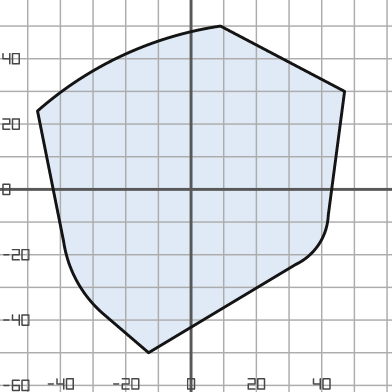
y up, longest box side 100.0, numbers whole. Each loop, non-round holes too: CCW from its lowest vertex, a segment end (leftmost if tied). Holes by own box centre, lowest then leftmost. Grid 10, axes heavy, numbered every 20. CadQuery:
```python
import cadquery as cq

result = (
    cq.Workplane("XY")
    .moveTo(-13.0, -50.0)
    .lineTo(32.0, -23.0)
    .threePointArc((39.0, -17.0), (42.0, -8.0))
    .lineTo(47.0, 30.0)
    .lineTo(9.0, 50.0)
    .threePointArc((-21.0, 41.0), (-47.0, 24.0))
    .lineTo(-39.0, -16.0)
    .threePointArc((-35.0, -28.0), (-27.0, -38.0))
    .close()
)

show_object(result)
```